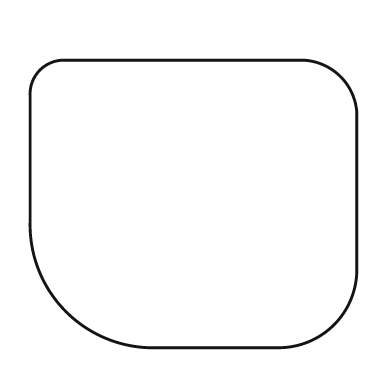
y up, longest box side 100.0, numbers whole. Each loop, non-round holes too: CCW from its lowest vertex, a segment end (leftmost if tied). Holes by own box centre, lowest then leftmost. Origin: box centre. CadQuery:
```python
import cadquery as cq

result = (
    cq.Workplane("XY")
    .moveTo(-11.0, -44.0)
    .lineTo(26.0, -44.0)
    .threePointArc((43.0, -37.0), (50.0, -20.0))
    .lineTo(50.0, 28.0)
    .threePointArc((45.0, 39.0), (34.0, 44.0))
    .lineTo(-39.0, 44.0)
    .threePointArc((-47.0, 41.0), (-50.0, 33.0))
    .lineTo(-50.0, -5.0)
    .threePointArc((-39.0, -33.0), (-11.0, -44.0))
    .close()
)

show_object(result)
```